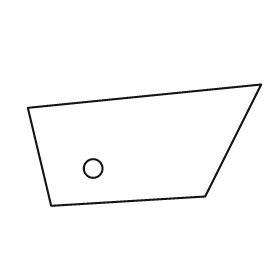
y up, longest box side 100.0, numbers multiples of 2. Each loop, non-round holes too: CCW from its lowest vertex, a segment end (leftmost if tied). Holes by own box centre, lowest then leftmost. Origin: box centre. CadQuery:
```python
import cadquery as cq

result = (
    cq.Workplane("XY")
    .moveTo(-40.0, -26.0)
    .lineTo(26.0, -22.0)
    .lineTo(50.0, 26.0)
    .lineTo(-50.0, 16.0)
    .close()
    .moveTo(-22.0, -10.0)
    .circle(4.0)
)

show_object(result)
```